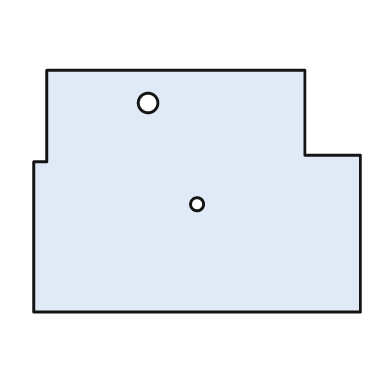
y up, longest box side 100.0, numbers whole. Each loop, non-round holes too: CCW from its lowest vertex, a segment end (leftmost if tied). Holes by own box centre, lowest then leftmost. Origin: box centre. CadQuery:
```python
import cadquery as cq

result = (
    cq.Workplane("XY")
    .moveTo(-50.0, -37.0)
    .lineTo(50.0, -37.0)
    .lineTo(50.0, 11.0)
    .lineTo(33.0, 11.0)
    .lineTo(33.0, 37.0)
    .lineTo(-46.0, 37.0)
    .lineTo(-46.0, 9.0)
    .lineTo(-50.0, 9.0)
    .close()
    .moveTo(0.0, -4.0)
    .circle(2.0)
    .moveTo(-15.0, 27.0)
    .circle(3.0)
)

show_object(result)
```